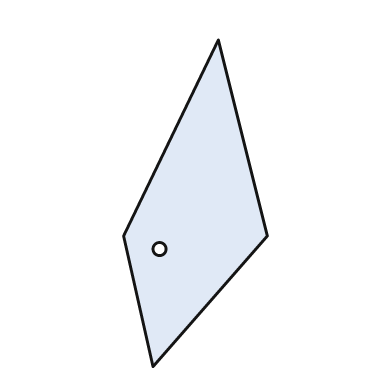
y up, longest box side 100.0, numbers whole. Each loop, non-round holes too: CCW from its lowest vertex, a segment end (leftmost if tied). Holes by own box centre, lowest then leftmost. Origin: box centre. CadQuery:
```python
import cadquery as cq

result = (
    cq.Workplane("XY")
    .moveTo(-13.0, -50.0)
    .lineTo(22.0, -10.0)
    .lineTo(7.0, 50.0)
    .lineTo(-22.0, -10.0)
    .close()
    .moveTo(-11.0, -14.0)
    .circle(2.0)
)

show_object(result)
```